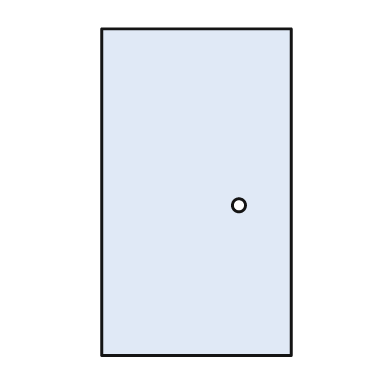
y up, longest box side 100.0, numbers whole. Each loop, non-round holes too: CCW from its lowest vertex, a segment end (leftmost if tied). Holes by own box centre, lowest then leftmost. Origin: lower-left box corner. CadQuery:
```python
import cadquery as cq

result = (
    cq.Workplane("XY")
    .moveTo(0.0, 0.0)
    .lineTo(58.0, 0.0)
    .lineTo(58.0, 100.0)
    .lineTo(0.0, 100.0)
    .close()
    .moveTo(42.0, 46.0)
    .circle(2.0)
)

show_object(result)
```